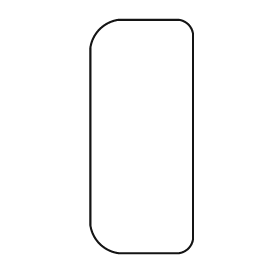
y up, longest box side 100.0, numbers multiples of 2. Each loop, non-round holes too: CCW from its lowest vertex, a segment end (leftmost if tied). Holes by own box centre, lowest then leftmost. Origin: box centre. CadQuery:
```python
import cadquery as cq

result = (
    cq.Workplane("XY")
    .moveTo(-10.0, -50.0)
    .lineTo(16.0, -50.0)
    .threePointArc((20.0, -48.0), (22.0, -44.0))
    .lineTo(22.0, 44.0)
    .threePointArc((20.0, 48.0), (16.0, 50.0))
    .lineTo(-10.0, 50.0)
    .threePointArc((-18.0, 46.0), (-22.0, 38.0))
    .lineTo(-22.0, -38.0)
    .threePointArc((-18.0, -46.0), (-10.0, -50.0))
    .close()
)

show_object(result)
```